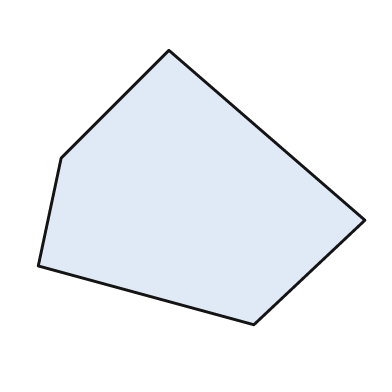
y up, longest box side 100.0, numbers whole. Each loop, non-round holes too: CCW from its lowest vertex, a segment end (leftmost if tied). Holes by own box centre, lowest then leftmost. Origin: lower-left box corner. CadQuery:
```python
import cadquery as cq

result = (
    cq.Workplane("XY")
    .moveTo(66.0, 0.0)
    .lineTo(100.0, 32.0)
    .lineTo(40.0, 84.0)
    .lineTo(7.0, 51.0)
    .lineTo(0.0, 18.0)
    .close()
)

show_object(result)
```